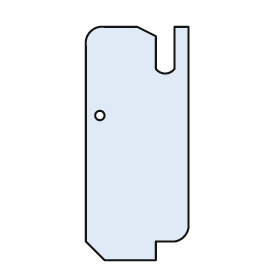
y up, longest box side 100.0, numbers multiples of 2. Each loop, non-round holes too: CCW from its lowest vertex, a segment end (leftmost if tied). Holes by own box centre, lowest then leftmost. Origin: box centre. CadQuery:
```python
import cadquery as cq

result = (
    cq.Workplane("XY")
    .moveTo(-14.0, -50.0)
    .lineTo(8.0, -50.0)
    .lineTo(8.0, -42.0)
    .lineTo(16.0, -42.0)
    .threePointArc((20.0, -40.0), (22.0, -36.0))
    .lineTo(22.0, 50.0)
    .lineTo(16.0, 50.0)
    .lineTo(16.0, 32.0)
    .threePointArc((12.0, 30.0), (8.0, 32.0))
    .lineTo(8.0, 46.0)
    .lineTo(0.0, 50.0)
    .lineTo(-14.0, 50.0)
    .threePointArc((-20.0, 48.0), (-22.0, 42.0))
    .lineTo(-22.0, -42.0)
    .close()
    .moveTo(-16.0, 12.0)
    .circle(2.0)
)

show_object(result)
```